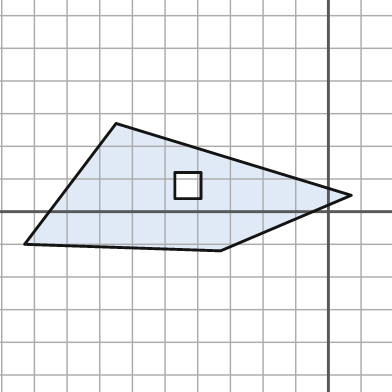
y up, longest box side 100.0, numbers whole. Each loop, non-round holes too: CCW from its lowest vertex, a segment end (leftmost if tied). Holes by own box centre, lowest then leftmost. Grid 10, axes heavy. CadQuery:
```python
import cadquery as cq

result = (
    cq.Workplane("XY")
    .moveTo(-33.0, -12.0)
    .lineTo(7.0, 5.0)
    .lineTo(-65.0, 27.0)
    .lineTo(-93.0, -10.0)
    .close()
    .moveTo(-47.0, 4.0)
    .lineTo(-39.0, 4.0)
    .lineTo(-39.0, 12.0)
    .lineTo(-47.0, 12.0)
    .close()
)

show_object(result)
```